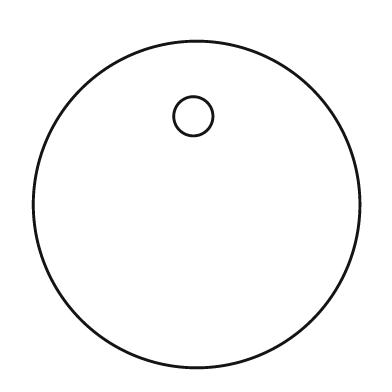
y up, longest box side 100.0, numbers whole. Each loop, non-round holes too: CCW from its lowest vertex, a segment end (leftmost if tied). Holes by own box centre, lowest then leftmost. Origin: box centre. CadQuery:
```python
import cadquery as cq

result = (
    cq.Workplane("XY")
    .moveTo(0.0, 0.0)
    .circle(50.0)
    .moveTo(-1.0, 27.0)
    .circle(6.0)
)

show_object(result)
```